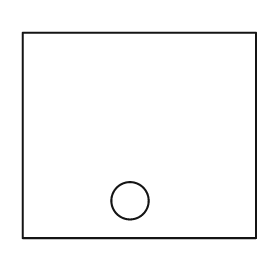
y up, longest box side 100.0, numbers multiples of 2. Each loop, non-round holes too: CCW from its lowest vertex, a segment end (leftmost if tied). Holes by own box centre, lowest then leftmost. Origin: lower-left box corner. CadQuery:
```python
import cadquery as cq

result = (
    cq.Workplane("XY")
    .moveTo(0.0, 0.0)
    .lineTo(100.0, 0.0)
    .lineTo(100.0, 88.0)
    .lineTo(0.0, 88.0)
    .close()
    .moveTo(46.0, 16.0)
    .circle(8.0)
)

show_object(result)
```